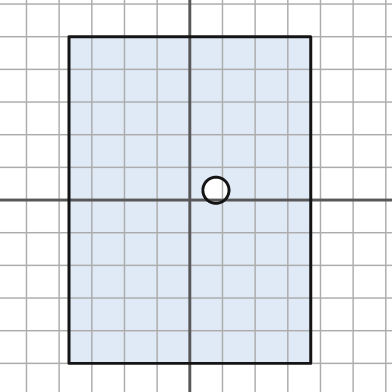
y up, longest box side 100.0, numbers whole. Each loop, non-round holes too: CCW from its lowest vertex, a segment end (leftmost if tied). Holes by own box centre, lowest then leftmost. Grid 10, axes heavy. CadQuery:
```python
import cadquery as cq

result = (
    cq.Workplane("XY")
    .moveTo(-37.0, -50.0)
    .lineTo(37.0, -50.0)
    .lineTo(37.0, 50.0)
    .lineTo(-37.0, 50.0)
    .close()
    .moveTo(8.0, 3.0)
    .circle(4.0)
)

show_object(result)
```